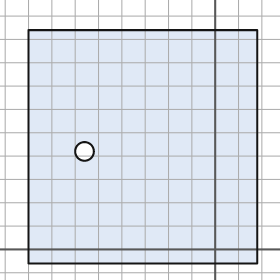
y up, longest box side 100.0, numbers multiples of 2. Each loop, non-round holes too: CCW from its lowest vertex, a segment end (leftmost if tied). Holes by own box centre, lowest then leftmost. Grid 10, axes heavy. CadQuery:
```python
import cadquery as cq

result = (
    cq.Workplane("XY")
    .moveTo(-80.0, -6.0)
    .lineTo(18.0, -6.0)
    .lineTo(18.0, 94.0)
    .lineTo(-80.0, 94.0)
    .close()
    .moveTo(-56.0, 42.0)
    .circle(4.0)
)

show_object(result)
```